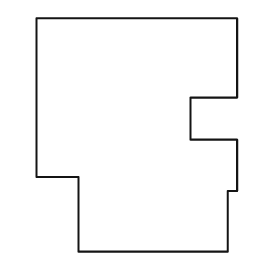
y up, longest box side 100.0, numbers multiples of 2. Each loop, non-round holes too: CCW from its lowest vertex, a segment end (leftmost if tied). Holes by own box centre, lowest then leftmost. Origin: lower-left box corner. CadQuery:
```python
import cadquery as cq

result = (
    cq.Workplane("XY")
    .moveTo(18.0, 0.0)
    .lineTo(82.0, 0.0)
    .lineTo(82.0, 26.0)
    .lineTo(86.0, 26.0)
    .lineTo(86.0, 48.0)
    .lineTo(66.0, 48.0)
    .lineTo(66.0, 66.0)
    .lineTo(86.0, 66.0)
    .lineTo(86.0, 100.0)
    .lineTo(0.0, 100.0)
    .lineTo(0.0, 32.0)
    .lineTo(18.0, 32.0)
    .close()
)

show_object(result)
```